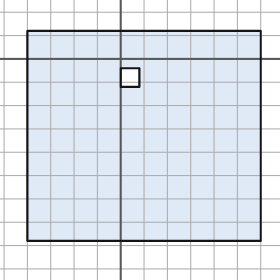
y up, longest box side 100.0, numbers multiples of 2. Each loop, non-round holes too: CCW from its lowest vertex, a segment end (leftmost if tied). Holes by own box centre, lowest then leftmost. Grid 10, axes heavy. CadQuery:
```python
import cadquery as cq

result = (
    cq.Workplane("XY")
    .moveTo(-40.0, -78.0)
    .lineTo(60.0, -78.0)
    .lineTo(60.0, 12.0)
    .lineTo(-40.0, 12.0)
    .close()
    .moveTo(0.0, -12.0)
    .lineTo(8.0, -12.0)
    .lineTo(8.0, -4.0)
    .lineTo(0.0, -4.0)
    .close()
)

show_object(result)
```